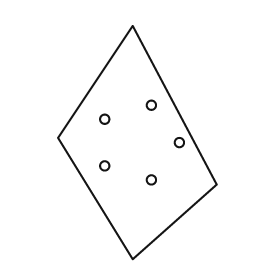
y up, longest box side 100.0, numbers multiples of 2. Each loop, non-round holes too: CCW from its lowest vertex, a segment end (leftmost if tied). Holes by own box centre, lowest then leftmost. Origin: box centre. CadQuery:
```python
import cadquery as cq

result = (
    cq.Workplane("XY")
    .moveTo(-2.0, -50.0)
    .lineTo(34.0, -18.0)
    .lineTo(-2.0, 50.0)
    .lineTo(-34.0, 2.0)
    .close()
    .moveTo(6.0, -16.0)
    .circle(2.0)
    .moveTo(-14.0, -10.0)
    .circle(2.0)
    .moveTo(18.0, 0.0)
    .circle(2.0)
    .moveTo(-14.0, 10.0)
    .circle(2.0)
    .moveTo(6.0, 16.0)
    .circle(2.0)
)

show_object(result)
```